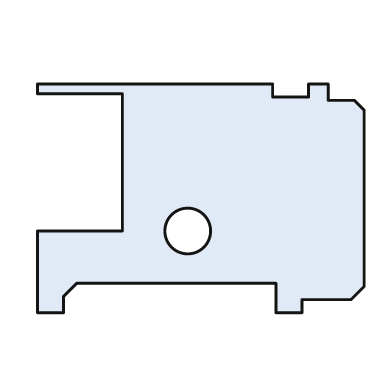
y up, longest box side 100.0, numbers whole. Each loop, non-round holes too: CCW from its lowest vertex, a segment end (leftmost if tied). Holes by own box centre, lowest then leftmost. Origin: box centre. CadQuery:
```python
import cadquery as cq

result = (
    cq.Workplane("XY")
    .moveTo(-50.0, -35.0)
    .lineTo(-42.0, -35.0)
    .lineTo(-42.0, -30.0)
    .lineTo(-38.0, -26.0)
    .lineTo(23.0, -26.0)
    .lineTo(23.0, -35.0)
    .lineTo(31.0, -35.0)
    .lineTo(31.0, -31.0)
    .lineTo(46.0, -31.0)
    .lineTo(50.0, -27.0)
    .lineTo(50.0, 27.0)
    .lineTo(47.0, 30.0)
    .lineTo(39.0, 30.0)
    .lineTo(39.0, 35.0)
    .lineTo(33.0, 35.0)
    .lineTo(33.0, 31.0)
    .lineTo(22.0, 31.0)
    .lineTo(22.0, 35.0)
    .lineTo(-50.0, 35.0)
    .lineTo(-50.0, 32.0)
    .lineTo(-24.0, 32.0)
    .lineTo(-24.0, -10.0)
    .lineTo(-50.0, -10.0)
    .close()
    .moveTo(-4.0, -10.0)
    .circle(7.0)
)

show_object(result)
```